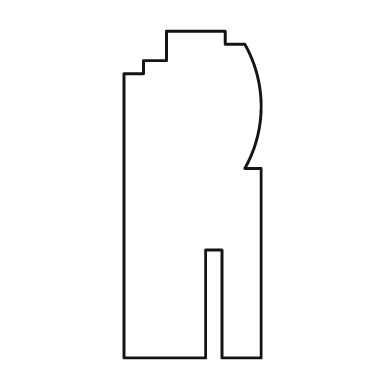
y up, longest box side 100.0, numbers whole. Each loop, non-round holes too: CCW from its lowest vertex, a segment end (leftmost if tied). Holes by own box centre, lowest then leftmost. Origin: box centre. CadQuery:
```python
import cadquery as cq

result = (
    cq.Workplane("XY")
    .moveTo(-21.0, -50.0)
    .lineTo(4.0, -50.0)
    .lineTo(4.0, -17.0)
    .lineTo(9.0, -17.0)
    .lineTo(9.0, -50.0)
    .lineTo(21.0, -50.0)
    .lineTo(21.0, 8.0)
    .lineTo(16.0, 8.0)
    .threePointArc((21.0, 27.0), (16.0, 46.0))
    .lineTo(10.0, 46.0)
    .lineTo(10.0, 50.0)
    .lineTo(-8.0, 50.0)
    .lineTo(-8.0, 41.0)
    .lineTo(-15.0, 41.0)
    .lineTo(-15.0, 37.0)
    .lineTo(-21.0, 37.0)
    .close()
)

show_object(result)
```